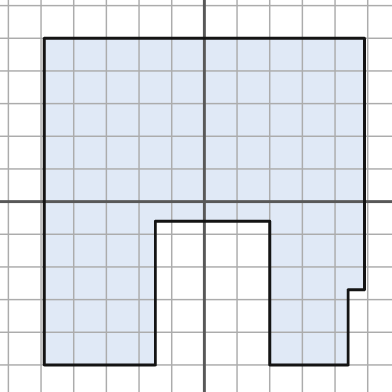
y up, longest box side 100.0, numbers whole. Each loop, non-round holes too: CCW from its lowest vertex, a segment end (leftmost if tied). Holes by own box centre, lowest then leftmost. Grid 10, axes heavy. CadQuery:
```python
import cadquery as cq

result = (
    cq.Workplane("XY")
    .moveTo(-49.0, -50.0)
    .lineTo(-15.0, -50.0)
    .lineTo(-15.0, -6.0)
    .lineTo(20.0, -6.0)
    .lineTo(20.0, -50.0)
    .lineTo(44.0, -50.0)
    .lineTo(44.0, -27.0)
    .lineTo(49.0, -27.0)
    .lineTo(49.0, 50.0)
    .lineTo(-49.0, 50.0)
    .close()
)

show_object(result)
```